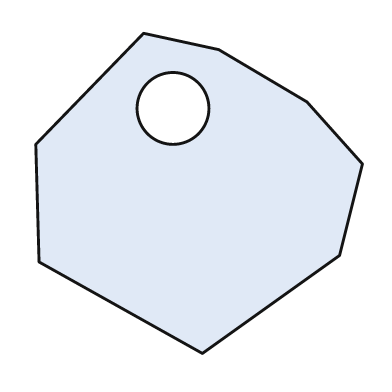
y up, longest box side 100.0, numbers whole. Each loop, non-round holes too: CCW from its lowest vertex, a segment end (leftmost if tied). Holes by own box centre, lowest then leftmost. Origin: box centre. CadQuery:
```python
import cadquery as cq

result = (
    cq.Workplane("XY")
    .moveTo(1.0, -49.0)
    .lineTo(43.0, -19.0)
    .lineTo(50.0, 9.0)
    .lineTo(33.0, 28.0)
    .lineTo(6.0, 44.0)
    .lineTo(-17.0, 49.0)
    .lineTo(-50.0, 15.0)
    .lineTo(-49.0, -21.0)
    .close()
    .moveTo(-8.0, 26.0)
    .circle(11.0)
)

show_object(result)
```